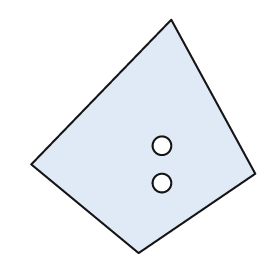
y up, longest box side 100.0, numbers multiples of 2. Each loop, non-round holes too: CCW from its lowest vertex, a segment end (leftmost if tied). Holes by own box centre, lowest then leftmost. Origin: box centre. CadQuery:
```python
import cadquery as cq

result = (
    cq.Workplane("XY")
    .moveTo(-2.0, -50.0)
    .lineTo(48.0, -16.0)
    .lineTo(12.0, 50.0)
    .lineTo(-48.0, -12.0)
    .close()
    .moveTo(8.0, -20.0)
    .circle(4.0)
    .moveTo(8.0, -4.0)
    .circle(4.0)
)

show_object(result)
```